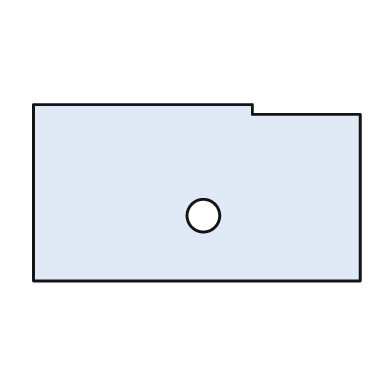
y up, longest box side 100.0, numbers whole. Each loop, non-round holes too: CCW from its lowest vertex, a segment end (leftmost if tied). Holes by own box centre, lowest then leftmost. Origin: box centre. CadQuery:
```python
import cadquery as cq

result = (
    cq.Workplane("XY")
    .moveTo(-50.0, -27.0)
    .lineTo(50.0, -27.0)
    .lineTo(50.0, 24.0)
    .lineTo(17.0, 24.0)
    .lineTo(17.0, 27.0)
    .lineTo(-50.0, 27.0)
    .close()
    .moveTo(2.0, -7.0)
    .circle(5.0)
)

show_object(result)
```